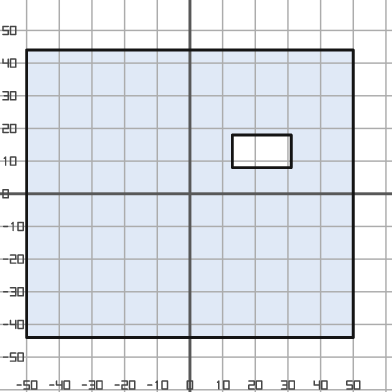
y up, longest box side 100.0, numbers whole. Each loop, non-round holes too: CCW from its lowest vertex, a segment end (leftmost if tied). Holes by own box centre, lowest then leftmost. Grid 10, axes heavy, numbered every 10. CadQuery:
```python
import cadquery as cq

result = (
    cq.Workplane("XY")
    .moveTo(-50.0, -44.0)
    .lineTo(50.0, -44.0)
    .lineTo(50.0, 44.0)
    .lineTo(-50.0, 44.0)
    .close()
    .moveTo(13.0, 8.0)
    .lineTo(31.0, 8.0)
    .lineTo(31.0, 18.0)
    .lineTo(13.0, 18.0)
    .close()
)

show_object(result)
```